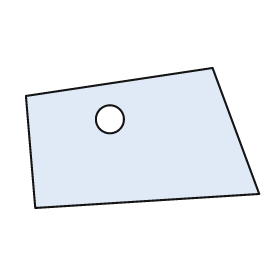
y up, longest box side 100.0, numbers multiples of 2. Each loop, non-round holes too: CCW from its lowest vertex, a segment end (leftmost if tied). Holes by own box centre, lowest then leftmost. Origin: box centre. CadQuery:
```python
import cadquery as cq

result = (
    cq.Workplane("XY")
    .moveTo(-46.0, -30.0)
    .lineTo(50.0, -24.0)
    .lineTo(30.0, 30.0)
    .lineTo(-50.0, 18.0)
    .close()
    .moveTo(-14.0, 8.0)
    .circle(6.0)
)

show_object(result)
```